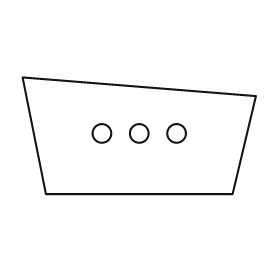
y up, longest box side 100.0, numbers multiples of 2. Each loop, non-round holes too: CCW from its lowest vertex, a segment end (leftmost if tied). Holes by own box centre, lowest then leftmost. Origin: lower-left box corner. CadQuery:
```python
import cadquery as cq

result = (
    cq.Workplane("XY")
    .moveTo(10.0, 0.0)
    .lineTo(90.0, 0.0)
    .lineTo(100.0, 42.0)
    .lineTo(0.0, 50.0)
    .close()
    .moveTo(34.0, 26.0)
    .circle(4.0)
    .moveTo(50.0, 26.0)
    .circle(4.0)
    .moveTo(66.0, 26.0)
    .circle(4.0)
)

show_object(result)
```